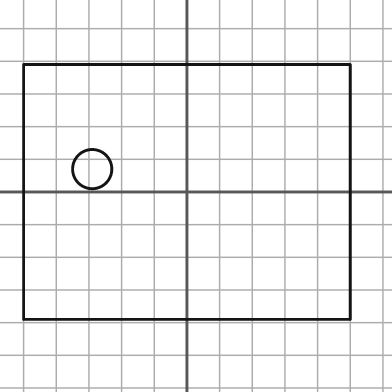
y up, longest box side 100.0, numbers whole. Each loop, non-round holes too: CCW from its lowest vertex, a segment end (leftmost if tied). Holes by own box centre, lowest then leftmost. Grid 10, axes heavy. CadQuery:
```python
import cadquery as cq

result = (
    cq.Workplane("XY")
    .moveTo(-50.0, -39.0)
    .lineTo(50.0, -39.0)
    .lineTo(50.0, 39.0)
    .lineTo(-50.0, 39.0)
    .close()
    .moveTo(-29.0, 7.0)
    .circle(6.0)
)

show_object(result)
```